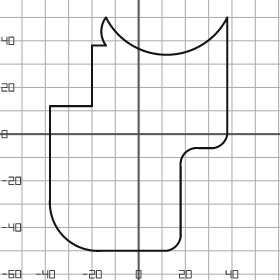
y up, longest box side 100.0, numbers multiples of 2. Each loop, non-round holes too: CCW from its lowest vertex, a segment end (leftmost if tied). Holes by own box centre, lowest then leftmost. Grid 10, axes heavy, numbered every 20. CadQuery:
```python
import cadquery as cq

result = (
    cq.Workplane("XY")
    .moveTo(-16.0, -50.0)
    .lineTo(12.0, -50.0)
    .threePointArc((16.0, -48.0), (18.0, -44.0))
    .lineTo(18.0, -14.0)
    .threePointArc((20.0, -8.0), (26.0, -6.0))
    .lineTo(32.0, -6.0)
    .threePointArc((36.0, -4.0), (38.0, 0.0))
    .lineTo(38.0, 50.0)
    .threePointArc((12.0, 34.0), (-14.0, 50.0))
    .threePointArc((-16.0, 44.0), (-14.0, 38.0))
    .lineTo(-20.0, 38.0)
    .lineTo(-20.0, 12.0)
    .lineTo(-38.0, 12.0)
    .lineTo(-38.0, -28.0)
    .threePointArc((-32.0, -44.0), (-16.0, -50.0))
    .close()
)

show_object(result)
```